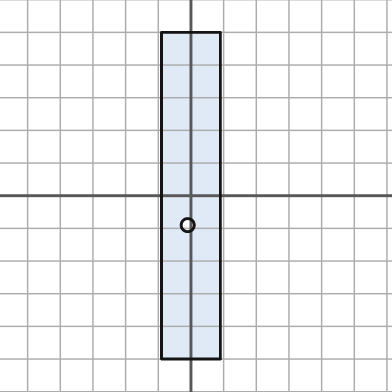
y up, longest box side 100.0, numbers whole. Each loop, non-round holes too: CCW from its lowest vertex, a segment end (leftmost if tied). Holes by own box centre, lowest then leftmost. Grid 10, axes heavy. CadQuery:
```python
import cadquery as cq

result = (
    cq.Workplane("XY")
    .moveTo(-9.0, -50.0)
    .lineTo(9.0, -50.0)
    .lineTo(9.0, 50.0)
    .lineTo(-9.0, 50.0)
    .close()
    .moveTo(-1.0, -9.0)
    .circle(2.0)
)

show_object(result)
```